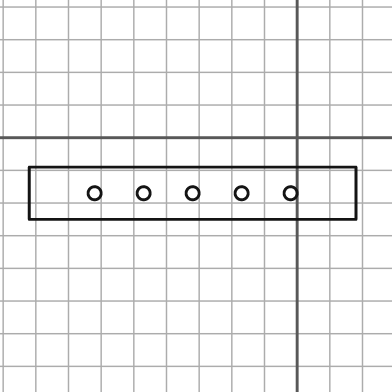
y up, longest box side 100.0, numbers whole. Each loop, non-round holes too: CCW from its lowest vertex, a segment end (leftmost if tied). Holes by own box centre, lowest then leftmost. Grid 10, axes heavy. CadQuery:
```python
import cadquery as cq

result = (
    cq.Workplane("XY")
    .moveTo(-82.0, -25.0)
    .lineTo(18.0, -25.0)
    .lineTo(18.0, -9.0)
    .lineTo(-82.0, -9.0)
    .close()
    .moveTo(-62.0, -17.0)
    .circle(2.0)
    .moveTo(-47.0, -17.0)
    .circle(2.0)
    .moveTo(-32.0, -17.0)
    .circle(2.0)
    .moveTo(-17.0, -17.0)
    .circle(2.0)
    .moveTo(-2.0, -17.0)
    .circle(2.0)
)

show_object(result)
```